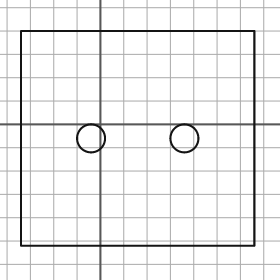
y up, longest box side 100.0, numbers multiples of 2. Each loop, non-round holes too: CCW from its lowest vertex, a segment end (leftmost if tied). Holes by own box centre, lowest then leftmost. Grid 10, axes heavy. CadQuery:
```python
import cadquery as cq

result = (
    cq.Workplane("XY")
    .moveTo(-34.0, -52.0)
    .lineTo(66.0, -52.0)
    .lineTo(66.0, 40.0)
    .lineTo(-34.0, 40.0)
    .close()
    .moveTo(-4.0, -6.0)
    .circle(6.0)
    .moveTo(36.0, -6.0)
    .circle(6.0)
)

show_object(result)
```